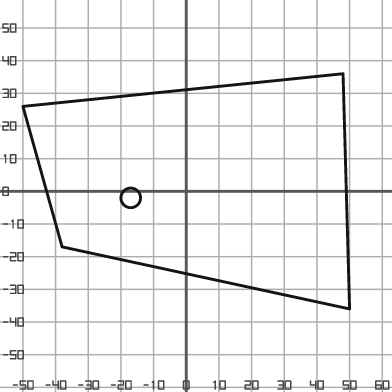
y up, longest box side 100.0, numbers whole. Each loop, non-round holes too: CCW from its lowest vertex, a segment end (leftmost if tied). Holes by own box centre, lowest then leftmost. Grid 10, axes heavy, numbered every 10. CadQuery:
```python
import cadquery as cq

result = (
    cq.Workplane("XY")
    .moveTo(50.0, -36.0)
    .lineTo(48.0, 36.0)
    .lineTo(-50.0, 26.0)
    .lineTo(-38.0, -17.0)
    .close()
    .moveTo(-17.0, -2.0)
    .circle(3.0)
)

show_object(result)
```